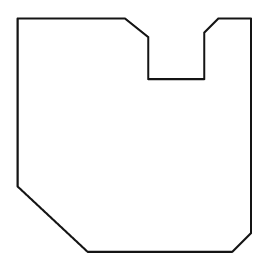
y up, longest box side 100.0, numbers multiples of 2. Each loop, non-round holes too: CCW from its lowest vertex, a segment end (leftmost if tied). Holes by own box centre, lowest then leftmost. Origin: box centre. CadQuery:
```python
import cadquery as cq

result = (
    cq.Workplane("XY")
    .moveTo(-20.0, -50.0)
    .lineTo(42.0, -50.0)
    .lineTo(50.0, -42.0)
    .lineTo(50.0, 50.0)
    .lineTo(36.0, 50.0)
    .lineTo(30.0, 44.0)
    .lineTo(30.0, 24.0)
    .lineTo(6.0, 24.0)
    .lineTo(6.0, 42.0)
    .lineTo(-4.0, 50.0)
    .lineTo(-50.0, 50.0)
    .lineTo(-50.0, -22.0)
    .close()
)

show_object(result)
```